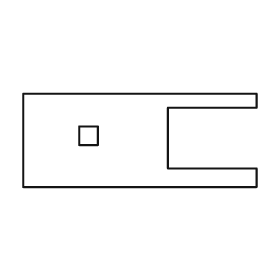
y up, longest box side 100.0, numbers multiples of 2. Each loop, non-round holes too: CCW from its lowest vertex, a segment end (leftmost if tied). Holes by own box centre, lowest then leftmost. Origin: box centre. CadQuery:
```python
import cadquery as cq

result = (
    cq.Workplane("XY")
    .moveTo(-50.0, -20.0)
    .lineTo(50.0, -20.0)
    .lineTo(50.0, -12.0)
    .lineTo(12.0, -12.0)
    .lineTo(12.0, 14.0)
    .lineTo(50.0, 14.0)
    .lineTo(50.0, 20.0)
    .lineTo(-50.0, 20.0)
    .close()
    .moveTo(-26.0, -2.0)
    .lineTo(-18.0, -2.0)
    .lineTo(-18.0, 6.0)
    .lineTo(-26.0, 6.0)
    .close()
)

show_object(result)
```